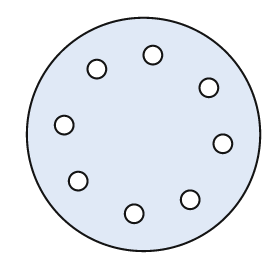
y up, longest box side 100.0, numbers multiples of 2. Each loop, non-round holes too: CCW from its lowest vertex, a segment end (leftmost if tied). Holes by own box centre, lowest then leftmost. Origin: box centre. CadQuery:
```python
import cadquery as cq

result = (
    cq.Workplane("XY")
    .moveTo(0.0, 0.0)
    .circle(50.0)
    .moveTo(-4.0, -34.0)
    .circle(4.0)
    .moveTo(20.0, -28.0)
    .circle(4.0)
    .moveTo(-28.0, -20.0)
    .circle(4.0)
    .moveTo(34.0, -4.0)
    .circle(4.0)
    .moveTo(-34.0, 4.0)
    .circle(4.0)
    .moveTo(28.0, 20.0)
    .circle(4.0)
    .moveTo(-20.0, 28.0)
    .circle(4.0)
    .moveTo(4.0, 34.0)
    .circle(4.0)
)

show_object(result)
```